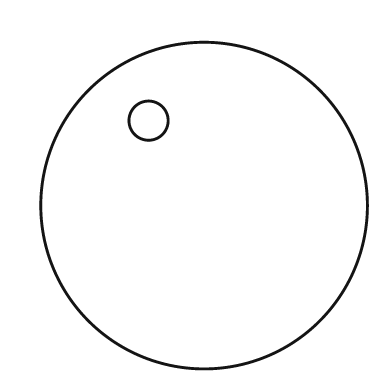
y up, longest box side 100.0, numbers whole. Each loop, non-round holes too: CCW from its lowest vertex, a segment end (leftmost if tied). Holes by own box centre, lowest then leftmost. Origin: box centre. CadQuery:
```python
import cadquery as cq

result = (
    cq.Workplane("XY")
    .moveTo(0.0, 0.0)
    .circle(50.0)
    .moveTo(-17.0, 26.0)
    .circle(6.0)
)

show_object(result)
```